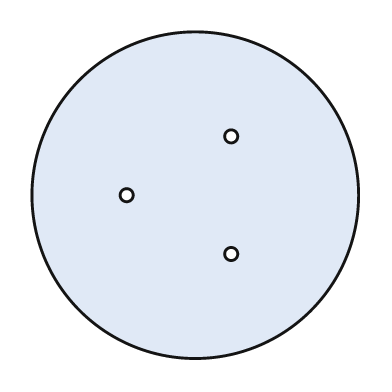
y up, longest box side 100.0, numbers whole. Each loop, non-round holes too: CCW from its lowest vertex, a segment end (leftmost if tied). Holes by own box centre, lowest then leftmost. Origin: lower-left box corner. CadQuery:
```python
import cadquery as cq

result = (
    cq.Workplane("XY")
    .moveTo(50.0, 50.0)
    .circle(50.0)
    .moveTo(61.0, 32.0)
    .circle(2.0)
    .moveTo(29.0, 50.0)
    .circle(2.0)
    .moveTo(61.0, 68.0)
    .circle(2.0)
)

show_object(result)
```